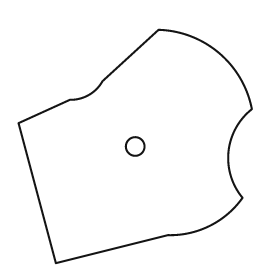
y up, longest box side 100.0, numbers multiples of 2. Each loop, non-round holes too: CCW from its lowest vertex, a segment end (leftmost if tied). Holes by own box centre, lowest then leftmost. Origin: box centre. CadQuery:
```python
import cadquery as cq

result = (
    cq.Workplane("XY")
    .moveTo(-34.0, -50.0)
    .lineTo(14.0, -38.0)
    .threePointArc((32.0, -34.0), (46.0, -22.0))
    .threePointArc((40.0, -2.0), (50.0, 16.0))
    .threePointArc((36.0, 40.0), (10.0, 50.0))
    .lineTo(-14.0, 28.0)
    .threePointArc((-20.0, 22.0), (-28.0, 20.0))
    .lineTo(-50.0, 10.0)
    .close()
    .moveTo(0.0, 0.0)
    .circle(4.0)
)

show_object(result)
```